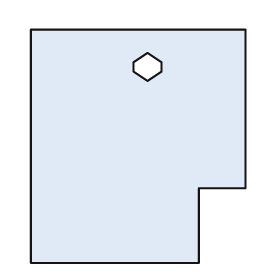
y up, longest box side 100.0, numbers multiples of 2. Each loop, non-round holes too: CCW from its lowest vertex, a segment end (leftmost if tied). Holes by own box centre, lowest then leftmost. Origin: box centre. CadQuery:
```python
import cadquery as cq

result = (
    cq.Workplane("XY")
    .moveTo(-46.0, -50.0)
    .lineTo(26.0, -50.0)
    .lineTo(26.0, -18.0)
    .lineTo(46.0, -18.0)
    .lineTo(46.0, 50.0)
    .lineTo(-46.0, 50.0)
    .close()
    .moveTo(4.0, 28.0)
    .lineTo(10.0, 32.0)
    .lineTo(10.0, 36.0)
    .lineTo(4.0, 40.0)
    .lineTo(-2.0, 36.0)
    .lineTo(-2.0, 32.0)
    .close()
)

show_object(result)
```